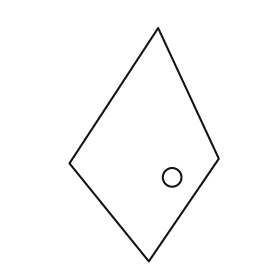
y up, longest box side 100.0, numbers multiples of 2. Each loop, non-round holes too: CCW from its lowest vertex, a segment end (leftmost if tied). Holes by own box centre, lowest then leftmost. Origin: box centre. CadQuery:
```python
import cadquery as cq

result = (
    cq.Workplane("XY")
    .moveTo(2.0, -50.0)
    .lineTo(32.0, -6.0)
    .lineTo(6.0, 50.0)
    .lineTo(-32.0, -8.0)
    .close()
    .moveTo(12.0, -14.0)
    .circle(4.0)
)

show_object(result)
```